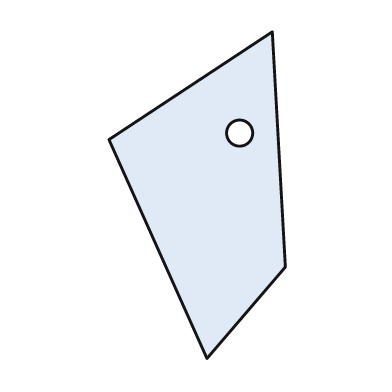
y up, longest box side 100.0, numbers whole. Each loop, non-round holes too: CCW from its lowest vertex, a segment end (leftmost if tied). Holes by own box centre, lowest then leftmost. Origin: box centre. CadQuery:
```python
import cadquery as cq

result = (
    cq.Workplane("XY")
    .moveTo(3.0, -50.0)
    .lineTo(27.0, -22.0)
    .lineTo(23.0, 50.0)
    .lineTo(-27.0, 17.0)
    .close()
    .moveTo(13.0, 19.0)
    .circle(4.0)
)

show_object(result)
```